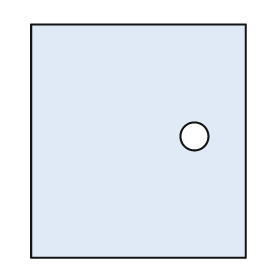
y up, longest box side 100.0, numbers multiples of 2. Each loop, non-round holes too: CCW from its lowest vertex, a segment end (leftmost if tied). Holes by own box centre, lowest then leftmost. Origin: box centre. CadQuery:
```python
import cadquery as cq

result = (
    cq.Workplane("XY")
    .moveTo(-46.0, -50.0)
    .lineTo(46.0, -50.0)
    .lineTo(46.0, 50.0)
    .lineTo(-46.0, 50.0)
    .close()
    .moveTo(24.0, 2.0)
    .circle(6.0)
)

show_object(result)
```